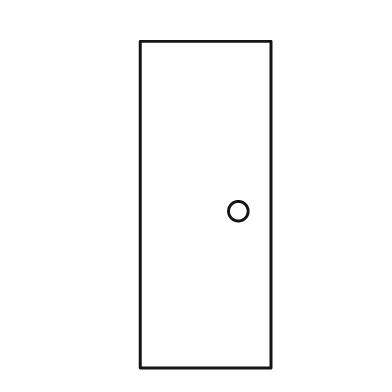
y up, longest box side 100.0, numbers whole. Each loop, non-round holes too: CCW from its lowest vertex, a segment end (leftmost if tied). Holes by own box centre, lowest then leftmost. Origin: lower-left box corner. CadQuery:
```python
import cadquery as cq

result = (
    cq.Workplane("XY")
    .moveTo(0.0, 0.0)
    .lineTo(40.0, 0.0)
    .lineTo(40.0, 100.0)
    .lineTo(0.0, 100.0)
    .close()
    .moveTo(30.0, 48.0)
    .circle(3.0)
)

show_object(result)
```